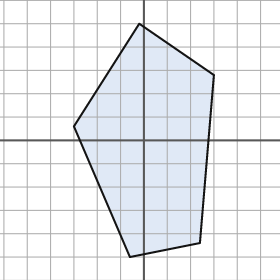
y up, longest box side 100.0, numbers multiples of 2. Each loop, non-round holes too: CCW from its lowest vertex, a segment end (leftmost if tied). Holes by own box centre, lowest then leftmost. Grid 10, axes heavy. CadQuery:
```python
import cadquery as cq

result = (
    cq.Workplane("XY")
    .moveTo(-6.0, -50.0)
    .lineTo(24.0, -44.0)
    .lineTo(30.0, 28.0)
    .lineTo(-2.0, 50.0)
    .lineTo(-30.0, 6.0)
    .close()
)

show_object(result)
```